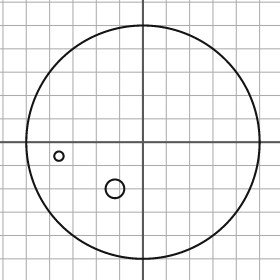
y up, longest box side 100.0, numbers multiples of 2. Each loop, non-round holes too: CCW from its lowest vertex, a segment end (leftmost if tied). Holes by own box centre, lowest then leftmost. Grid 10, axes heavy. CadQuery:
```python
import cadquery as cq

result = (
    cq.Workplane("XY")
    .moveTo(0.0, 0.0)
    .circle(50.0)
    .moveTo(-12.0, -20.0)
    .circle(4.0)
    .moveTo(-36.0, -6.0)
    .circle(2.0)
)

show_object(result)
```